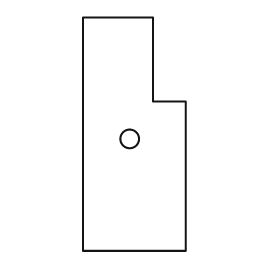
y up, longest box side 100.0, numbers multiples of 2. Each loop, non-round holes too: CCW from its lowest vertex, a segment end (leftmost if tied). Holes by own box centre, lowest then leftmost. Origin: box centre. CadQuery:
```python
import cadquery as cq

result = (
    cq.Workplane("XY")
    .moveTo(-22.0, -50.0)
    .lineTo(22.0, -50.0)
    .lineTo(22.0, 14.0)
    .lineTo(8.0, 14.0)
    .lineTo(8.0, 50.0)
    .lineTo(-22.0, 50.0)
    .close()
    .moveTo(-2.0, -2.0)
    .circle(4.0)
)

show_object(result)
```